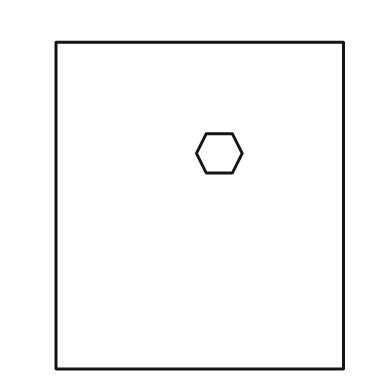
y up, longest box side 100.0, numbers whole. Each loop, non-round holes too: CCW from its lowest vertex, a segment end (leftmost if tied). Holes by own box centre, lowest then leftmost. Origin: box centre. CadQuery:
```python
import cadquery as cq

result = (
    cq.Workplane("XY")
    .moveTo(-44.0, -50.0)
    .lineTo(44.0, -50.0)
    .lineTo(44.0, 50.0)
    .lineTo(-44.0, 50.0)
    .close()
    .moveTo(2.0, 10.0)
    .lineTo(10.0, 10.0)
    .lineTo(13.0, 16.0)
    .lineTo(10.0, 22.0)
    .lineTo(2.0, 22.0)
    .lineTo(-1.0, 16.0)
    .close()
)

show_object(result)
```